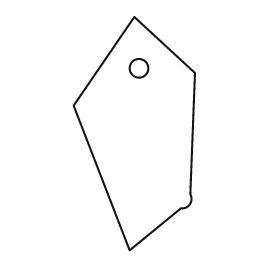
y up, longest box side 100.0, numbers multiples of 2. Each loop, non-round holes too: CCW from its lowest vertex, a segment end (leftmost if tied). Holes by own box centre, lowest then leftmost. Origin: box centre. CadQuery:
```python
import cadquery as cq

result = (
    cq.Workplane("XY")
    .moveTo(-2.0, -50.0)
    .lineTo(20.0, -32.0)
    .threePointArc((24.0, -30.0), (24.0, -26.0))
    .lineTo(26.0, 26.0)
    .lineTo(0.0, 50.0)
    .lineTo(-26.0, 12.0)
    .close()
    .moveTo(2.0, 28.0)
    .circle(4.0)
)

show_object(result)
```